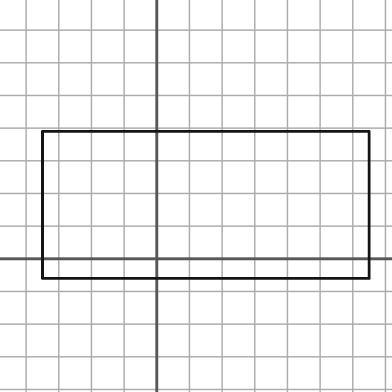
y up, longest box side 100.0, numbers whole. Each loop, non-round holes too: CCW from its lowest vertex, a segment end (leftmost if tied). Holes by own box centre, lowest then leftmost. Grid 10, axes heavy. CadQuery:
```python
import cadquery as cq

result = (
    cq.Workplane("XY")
    .moveTo(-35.0, -6.0)
    .lineTo(65.0, -6.0)
    .lineTo(65.0, 39.0)
    .lineTo(-35.0, 39.0)
    .close()
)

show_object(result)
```